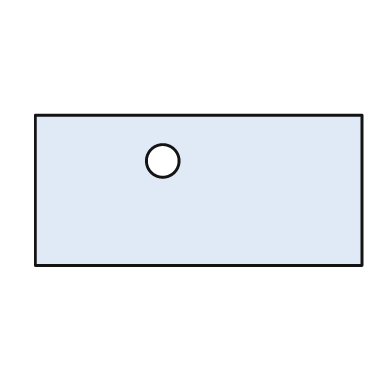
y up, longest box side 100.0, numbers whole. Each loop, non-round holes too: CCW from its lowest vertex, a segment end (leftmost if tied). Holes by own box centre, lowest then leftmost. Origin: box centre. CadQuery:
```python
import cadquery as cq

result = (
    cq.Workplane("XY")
    .moveTo(-50.0, -23.0)
    .lineTo(50.0, -23.0)
    .lineTo(50.0, 23.0)
    .lineTo(-50.0, 23.0)
    .close()
    .moveTo(-11.0, 9.0)
    .circle(5.0)
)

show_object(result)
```